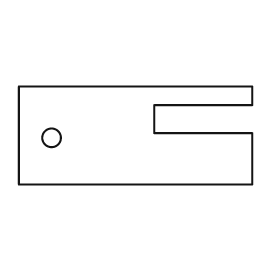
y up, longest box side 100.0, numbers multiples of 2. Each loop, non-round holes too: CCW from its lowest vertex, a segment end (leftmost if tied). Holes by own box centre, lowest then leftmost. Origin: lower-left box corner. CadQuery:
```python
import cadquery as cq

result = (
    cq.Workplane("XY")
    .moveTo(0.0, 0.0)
    .lineTo(100.0, 0.0)
    .lineTo(100.0, 22.0)
    .lineTo(58.0, 22.0)
    .lineTo(58.0, 34.0)
    .lineTo(100.0, 34.0)
    .lineTo(100.0, 42.0)
    .lineTo(0.0, 42.0)
    .close()
    .moveTo(14.0, 20.0)
    .circle(4.0)
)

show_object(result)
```